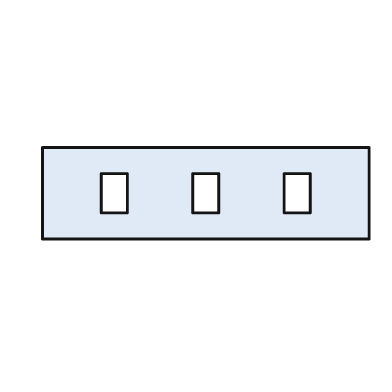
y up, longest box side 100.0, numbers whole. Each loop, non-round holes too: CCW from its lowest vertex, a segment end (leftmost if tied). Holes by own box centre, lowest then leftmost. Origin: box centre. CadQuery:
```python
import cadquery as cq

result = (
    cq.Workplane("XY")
    .moveTo(-50.0, -14.0)
    .lineTo(50.0, -14.0)
    .lineTo(50.0, 14.0)
    .lineTo(-50.0, 14.0)
    .close()
    .moveTo(-32.0, -6.0)
    .lineTo(-24.0, -6.0)
    .lineTo(-24.0, 6.0)
    .lineTo(-32.0, 6.0)
    .close()
    .moveTo(-4.0, -6.0)
    .lineTo(4.0, -6.0)
    .lineTo(4.0, 6.0)
    .lineTo(-4.0, 6.0)
    .close()
    .moveTo(24.0, -6.0)
    .lineTo(32.0, -6.0)
    .lineTo(32.0, 6.0)
    .lineTo(24.0, 6.0)
    .close()
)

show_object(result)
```